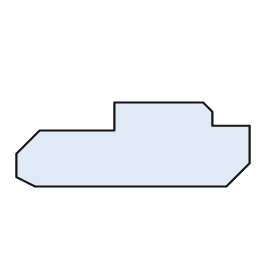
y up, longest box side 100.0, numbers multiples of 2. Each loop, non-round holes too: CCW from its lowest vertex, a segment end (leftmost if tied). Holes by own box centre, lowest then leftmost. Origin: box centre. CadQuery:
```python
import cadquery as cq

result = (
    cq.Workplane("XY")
    .moveTo(-42.0, -18.0)
    .lineTo(40.0, -18.0)
    .lineTo(50.0, -8.0)
    .lineTo(50.0, 8.0)
    .lineTo(34.0, 8.0)
    .lineTo(34.0, 14.0)
    .lineTo(30.0, 18.0)
    .lineTo(-8.0, 18.0)
    .lineTo(-8.0, 6.0)
    .lineTo(-40.0, 6.0)
    .lineTo(-50.0, -4.0)
    .lineTo(-50.0, -14.0)
    .close()
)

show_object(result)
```